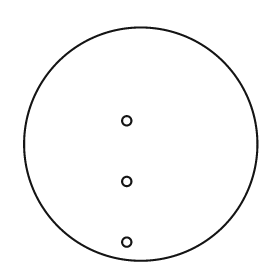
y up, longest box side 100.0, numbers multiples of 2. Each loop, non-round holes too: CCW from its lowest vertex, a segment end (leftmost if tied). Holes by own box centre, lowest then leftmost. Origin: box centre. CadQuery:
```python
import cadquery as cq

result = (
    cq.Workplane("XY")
    .moveTo(0.0, 0.0)
    .circle(50.0)
    .moveTo(-6.0, -42.0)
    .circle(2.0)
    .moveTo(-6.0, -16.0)
    .circle(2.0)
    .moveTo(-6.0, 10.0)
    .circle(2.0)
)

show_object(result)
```